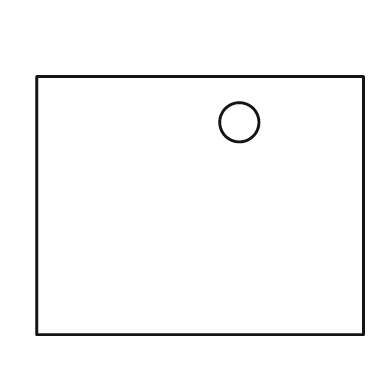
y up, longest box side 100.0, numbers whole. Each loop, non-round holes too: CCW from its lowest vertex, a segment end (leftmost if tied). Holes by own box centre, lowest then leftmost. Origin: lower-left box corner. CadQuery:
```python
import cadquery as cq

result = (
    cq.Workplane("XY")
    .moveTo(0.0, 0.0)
    .lineTo(100.0, 0.0)
    .lineTo(100.0, 79.0)
    .lineTo(0.0, 79.0)
    .close()
    .moveTo(62.0, 65.0)
    .circle(6.0)
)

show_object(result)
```